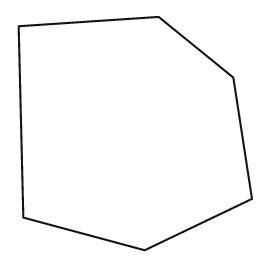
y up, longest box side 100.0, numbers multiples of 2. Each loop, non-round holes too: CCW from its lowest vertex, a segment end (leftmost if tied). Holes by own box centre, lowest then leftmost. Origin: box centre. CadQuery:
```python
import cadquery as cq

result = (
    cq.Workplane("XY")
    .moveTo(4.0, -50.0)
    .lineTo(50.0, -28.0)
    .lineTo(42.0, 24.0)
    .lineTo(10.0, 50.0)
    .lineTo(-50.0, 46.0)
    .lineTo(-48.0, -36.0)
    .close()
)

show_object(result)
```